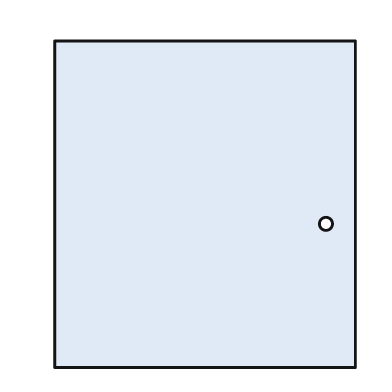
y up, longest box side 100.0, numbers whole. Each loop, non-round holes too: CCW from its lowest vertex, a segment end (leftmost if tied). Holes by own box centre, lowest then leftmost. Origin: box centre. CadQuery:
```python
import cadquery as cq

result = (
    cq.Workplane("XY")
    .moveTo(-46.0, -50.0)
    .lineTo(46.0, -50.0)
    .lineTo(46.0, 50.0)
    .lineTo(-46.0, 50.0)
    .close()
    .moveTo(37.0, -6.0)
    .circle(2.0)
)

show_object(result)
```